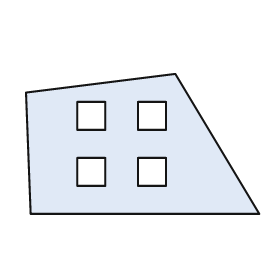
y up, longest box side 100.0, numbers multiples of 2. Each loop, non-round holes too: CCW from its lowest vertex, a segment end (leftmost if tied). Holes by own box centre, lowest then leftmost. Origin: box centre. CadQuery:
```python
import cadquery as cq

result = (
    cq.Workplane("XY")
    .moveTo(-48.0, -30.0)
    .lineTo(50.0, -30.0)
    .lineTo(14.0, 30.0)
    .lineTo(-50.0, 22.0)
    .close()
    .moveTo(-28.0, -18.0)
    .lineTo(-16.0, -18.0)
    .lineTo(-16.0, -6.0)
    .lineTo(-28.0, -6.0)
    .close()
    .moveTo(-2.0, -18.0)
    .lineTo(10.0, -18.0)
    .lineTo(10.0, -6.0)
    .lineTo(-2.0, -6.0)
    .close()
    .moveTo(-28.0, 6.0)
    .lineTo(-16.0, 6.0)
    .lineTo(-16.0, 18.0)
    .lineTo(-28.0, 18.0)
    .close()
    .moveTo(-2.0, 6.0)
    .lineTo(10.0, 6.0)
    .lineTo(10.0, 18.0)
    .lineTo(-2.0, 18.0)
    .close()
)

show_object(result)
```